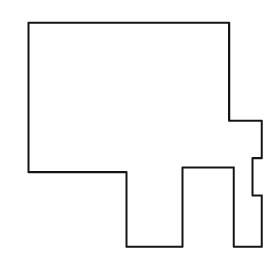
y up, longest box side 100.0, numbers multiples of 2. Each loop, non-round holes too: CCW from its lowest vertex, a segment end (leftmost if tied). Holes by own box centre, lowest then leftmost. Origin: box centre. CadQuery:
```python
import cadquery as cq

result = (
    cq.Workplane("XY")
    .moveTo(-8.0, -48.0)
    .lineTo(16.0, -48.0)
    .lineTo(16.0, -14.0)
    .lineTo(38.0, -14.0)
    .lineTo(38.0, -48.0)
    .lineTo(50.0, -48.0)
    .lineTo(50.0, -26.0)
    .lineTo(46.0, -26.0)
    .lineTo(46.0, -10.0)
    .lineTo(50.0, -10.0)
    .lineTo(50.0, 6.0)
    .lineTo(36.0, 6.0)
    .lineTo(36.0, 48.0)
    .lineTo(-50.0, 48.0)
    .lineTo(-50.0, -16.0)
    .lineTo(-8.0, -16.0)
    .close()
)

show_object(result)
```